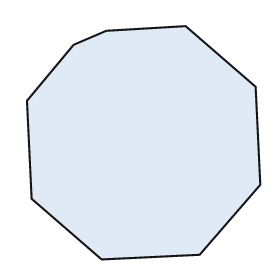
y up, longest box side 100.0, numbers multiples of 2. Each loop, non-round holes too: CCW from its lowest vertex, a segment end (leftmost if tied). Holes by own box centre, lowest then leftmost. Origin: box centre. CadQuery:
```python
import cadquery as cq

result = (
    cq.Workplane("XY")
    .moveTo(-18.0, -50.0)
    .lineTo(24.0, -48.0)
    .lineTo(50.0, -18.0)
    .lineTo(48.0, 24.0)
    .lineTo(18.0, 50.0)
    .lineTo(-16.0, 48.0)
    .lineTo(-30.0, 42.0)
    .lineTo(-50.0, 18.0)
    .lineTo(-48.0, -24.0)
    .close()
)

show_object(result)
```